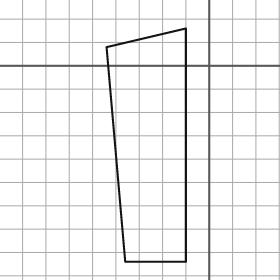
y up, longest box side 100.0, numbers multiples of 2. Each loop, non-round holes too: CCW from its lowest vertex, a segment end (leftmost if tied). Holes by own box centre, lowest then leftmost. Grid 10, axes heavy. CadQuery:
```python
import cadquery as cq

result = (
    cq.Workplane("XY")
    .moveTo(-36.0, -84.0)
    .lineTo(-10.0, -84.0)
    .lineTo(-10.0, 16.0)
    .lineTo(-44.0, 8.0)
    .close()
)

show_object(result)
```